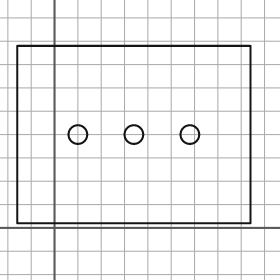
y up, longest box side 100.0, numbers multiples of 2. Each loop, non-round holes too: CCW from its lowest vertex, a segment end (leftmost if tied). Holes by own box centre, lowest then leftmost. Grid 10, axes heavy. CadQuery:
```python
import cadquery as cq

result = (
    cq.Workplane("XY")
    .moveTo(-16.0, 2.0)
    .lineTo(84.0, 2.0)
    .lineTo(84.0, 78.0)
    .lineTo(-16.0, 78.0)
    .close()
    .moveTo(10.0, 40.0)
    .circle(4.0)
    .moveTo(34.0, 40.0)
    .circle(4.0)
    .moveTo(58.0, 40.0)
    .circle(4.0)
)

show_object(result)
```